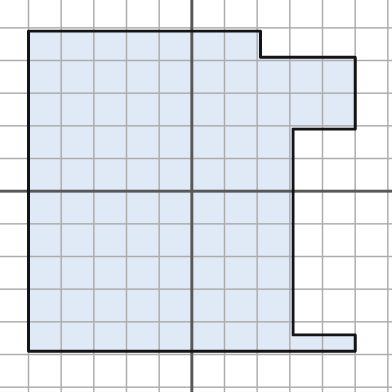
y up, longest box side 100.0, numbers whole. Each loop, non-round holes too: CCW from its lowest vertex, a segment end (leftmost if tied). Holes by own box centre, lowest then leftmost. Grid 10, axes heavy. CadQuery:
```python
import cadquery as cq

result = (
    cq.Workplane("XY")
    .moveTo(-50.0, -49.0)
    .lineTo(50.0, -49.0)
    .lineTo(50.0, -44.0)
    .lineTo(31.0, -44.0)
    .lineTo(31.0, 19.0)
    .lineTo(50.0, 19.0)
    .lineTo(50.0, 41.0)
    .lineTo(21.0, 41.0)
    .lineTo(21.0, 49.0)
    .lineTo(-50.0, 49.0)
    .close()
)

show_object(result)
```